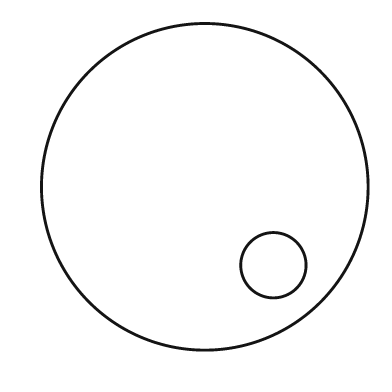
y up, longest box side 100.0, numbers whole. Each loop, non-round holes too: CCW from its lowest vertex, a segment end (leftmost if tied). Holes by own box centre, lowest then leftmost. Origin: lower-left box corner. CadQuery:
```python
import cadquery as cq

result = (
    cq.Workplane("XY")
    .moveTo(50.0, 50.0)
    .circle(50.0)
    .moveTo(71.0, 26.0)
    .circle(10.0)
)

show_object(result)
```